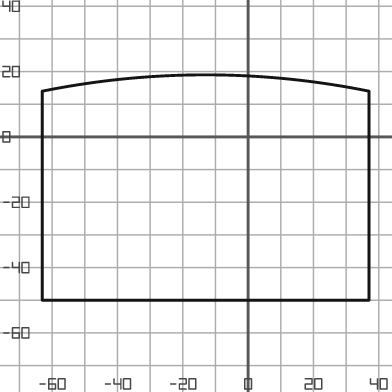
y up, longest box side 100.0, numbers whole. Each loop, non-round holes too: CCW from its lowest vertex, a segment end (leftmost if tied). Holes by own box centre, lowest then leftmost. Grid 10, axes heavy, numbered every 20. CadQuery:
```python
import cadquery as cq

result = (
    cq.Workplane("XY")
    .moveTo(-63.0, -50.0)
    .lineTo(37.0, -50.0)
    .lineTo(37.0, 14.0)
    .threePointArc((-13.0, 19.0), (-63.0, 14.0))
    .close()
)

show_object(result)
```